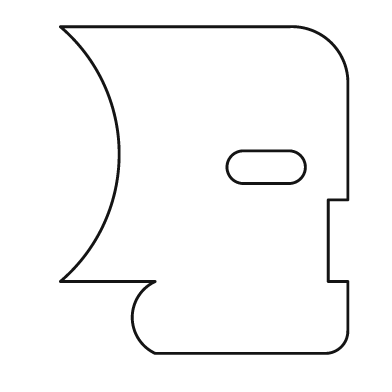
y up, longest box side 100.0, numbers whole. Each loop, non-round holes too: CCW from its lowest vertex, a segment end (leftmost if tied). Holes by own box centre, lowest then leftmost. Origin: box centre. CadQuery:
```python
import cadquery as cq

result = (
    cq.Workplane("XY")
    .moveTo(-15.0, -50.0)
    .lineTo(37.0, -50.0)
    .threePointArc((42.0, -48.0), (44.0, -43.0))
    .lineTo(44.0, -28.0)
    .lineTo(38.0, -28.0)
    .lineTo(38.0, -3.0)
    .lineTo(44.0, -3.0)
    .lineTo(44.0, 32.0)
    .threePointArc((39.0, 45.0), (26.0, 50.0))
    .lineTo(-44.0, 50.0)
    .threePointArc((-26.0, 11.0), (-44.0, -28.0))
    .lineTo(-15.0, -28.0)
    .threePointArc((-22.0, -39.0), (-15.0, -50.0))
    .close()
    .moveTo(12.0, 2.0)
    .lineTo(26.0, 2.0)
    .threePointArc((31.0, 7.0), (26.0, 12.0))
    .lineTo(12.0, 12.0)
    .threePointArc((7.0, 7.0), (12.0, 2.0))
    .close()
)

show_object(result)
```